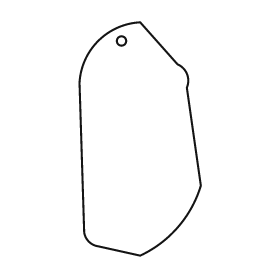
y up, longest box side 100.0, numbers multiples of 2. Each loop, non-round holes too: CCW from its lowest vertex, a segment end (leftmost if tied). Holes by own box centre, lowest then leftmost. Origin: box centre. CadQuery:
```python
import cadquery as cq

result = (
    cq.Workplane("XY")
    .moveTo(0.0, -50.0)
    .threePointArc((16.0, -38.0), (26.0, -20.0))
    .lineTo(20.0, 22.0)
    .threePointArc((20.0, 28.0), (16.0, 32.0))
    .lineTo(0.0, 50.0)
    .threePointArc((-18.0, 42.0), (-26.0, 24.0))
    .lineTo(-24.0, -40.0)
    .threePointArc((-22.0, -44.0), (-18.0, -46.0))
    .close()
    .moveTo(-8.0, 42.0)
    .circle(2.0)
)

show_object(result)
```